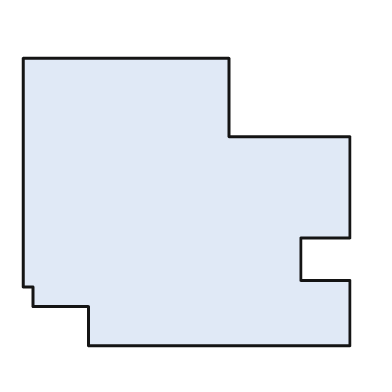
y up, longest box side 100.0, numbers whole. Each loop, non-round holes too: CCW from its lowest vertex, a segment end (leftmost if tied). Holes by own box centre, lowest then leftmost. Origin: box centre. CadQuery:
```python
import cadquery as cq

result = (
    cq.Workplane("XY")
    .moveTo(-30.0, -44.0)
    .lineTo(50.0, -44.0)
    .lineTo(50.0, -24.0)
    .lineTo(35.0, -24.0)
    .lineTo(35.0, -11.0)
    .lineTo(50.0, -11.0)
    .lineTo(50.0, 20.0)
    .lineTo(13.0, 20.0)
    .lineTo(13.0, 44.0)
    .lineTo(-50.0, 44.0)
    .lineTo(-50.0, -26.0)
    .lineTo(-47.0, -26.0)
    .lineTo(-47.0, -32.0)
    .lineTo(-30.0, -32.0)
    .close()
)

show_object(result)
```